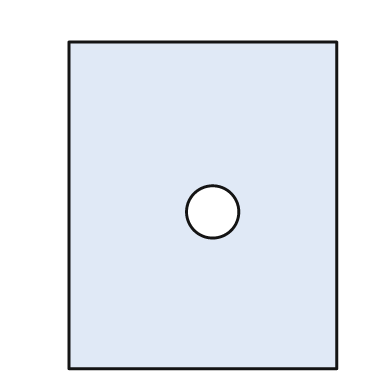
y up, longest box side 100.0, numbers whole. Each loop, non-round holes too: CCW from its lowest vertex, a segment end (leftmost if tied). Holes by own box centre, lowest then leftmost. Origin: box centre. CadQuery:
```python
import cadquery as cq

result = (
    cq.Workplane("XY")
    .moveTo(-41.0, -50.0)
    .lineTo(41.0, -50.0)
    .lineTo(41.0, 50.0)
    .lineTo(-41.0, 50.0)
    .close()
    .moveTo(3.0, -2.0)
    .circle(8.0)
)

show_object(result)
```